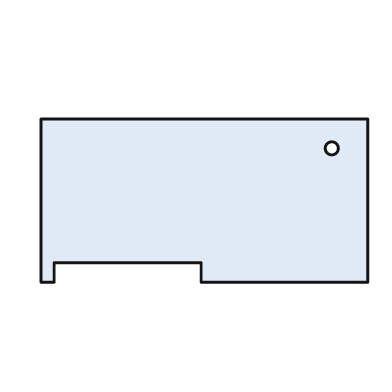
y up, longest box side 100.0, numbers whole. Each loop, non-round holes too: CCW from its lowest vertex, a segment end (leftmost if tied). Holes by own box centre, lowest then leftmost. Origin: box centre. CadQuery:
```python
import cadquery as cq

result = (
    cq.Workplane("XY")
    .moveTo(-50.0, -25.0)
    .lineTo(-46.0, -25.0)
    .lineTo(-46.0, -19.0)
    .lineTo(-1.0, -19.0)
    .lineTo(-1.0, -25.0)
    .lineTo(50.0, -25.0)
    .lineTo(50.0, 25.0)
    .lineTo(-50.0, 25.0)
    .close()
    .moveTo(39.0, 16.0)
    .circle(2.0)
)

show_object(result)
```